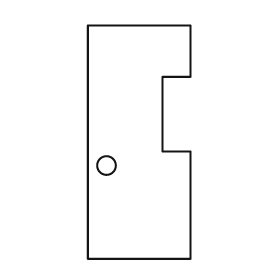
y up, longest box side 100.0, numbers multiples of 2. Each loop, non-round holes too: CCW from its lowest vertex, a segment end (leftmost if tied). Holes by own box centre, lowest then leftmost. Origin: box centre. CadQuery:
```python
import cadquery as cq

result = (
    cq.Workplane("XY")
    .moveTo(-22.0, -50.0)
    .lineTo(22.0, -50.0)
    .lineTo(22.0, -4.0)
    .lineTo(10.0, -4.0)
    .lineTo(10.0, 28.0)
    .lineTo(22.0, 28.0)
    .lineTo(22.0, 50.0)
    .lineTo(-22.0, 50.0)
    .close()
    .moveTo(-14.0, -10.0)
    .circle(4.0)
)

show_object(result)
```